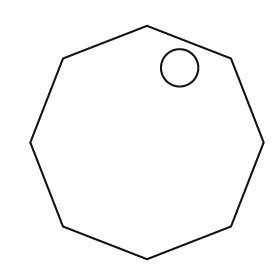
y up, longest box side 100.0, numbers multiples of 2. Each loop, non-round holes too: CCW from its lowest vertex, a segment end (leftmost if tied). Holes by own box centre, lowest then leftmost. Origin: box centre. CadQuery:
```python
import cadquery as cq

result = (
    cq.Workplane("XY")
    .moveTo(0.0, -50.0)
    .lineTo(36.0, -36.0)
    .lineTo(50.0, 0.0)
    .lineTo(36.0, 36.0)
    .lineTo(0.0, 50.0)
    .lineTo(-36.0, 36.0)
    .lineTo(-50.0, 0.0)
    .lineTo(-36.0, -36.0)
    .close()
    .moveTo(14.0, 32.0)
    .circle(8.0)
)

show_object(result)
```